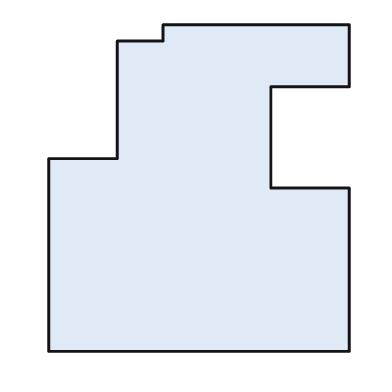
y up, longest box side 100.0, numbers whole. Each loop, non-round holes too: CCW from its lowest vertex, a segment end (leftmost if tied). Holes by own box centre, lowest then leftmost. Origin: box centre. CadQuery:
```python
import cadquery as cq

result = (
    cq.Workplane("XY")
    .moveTo(-46.0, -50.0)
    .lineTo(46.0, -50.0)
    .lineTo(46.0, 0.0)
    .lineTo(22.0, 0.0)
    .lineTo(22.0, 31.0)
    .lineTo(46.0, 31.0)
    .lineTo(46.0, 50.0)
    .lineTo(-11.0, 50.0)
    .lineTo(-11.0, 45.0)
    .lineTo(-25.0, 45.0)
    .lineTo(-25.0, 9.0)
    .lineTo(-46.0, 9.0)
    .close()
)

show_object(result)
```